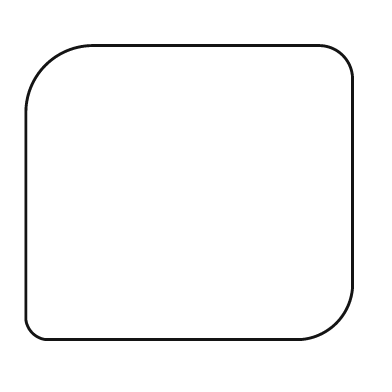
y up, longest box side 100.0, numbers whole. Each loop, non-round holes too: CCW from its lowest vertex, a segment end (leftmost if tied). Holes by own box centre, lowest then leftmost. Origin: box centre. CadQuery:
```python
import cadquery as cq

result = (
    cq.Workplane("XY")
    .moveTo(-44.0, -45.0)
    .lineTo(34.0, -45.0)
    .threePointArc((45.0, -40.0), (50.0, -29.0))
    .lineTo(50.0, 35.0)
    .threePointArc((47.0, 42.0), (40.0, 45.0))
    .lineTo(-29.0, 45.0)
    .threePointArc((-44.0, 39.0), (-50.0, 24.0))
    .lineTo(-50.0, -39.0)
    .threePointArc((-48.0, -43.0), (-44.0, -45.0))
    .close()
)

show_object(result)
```